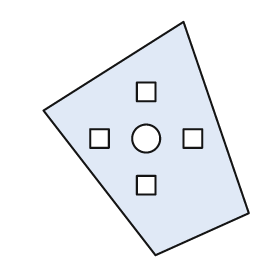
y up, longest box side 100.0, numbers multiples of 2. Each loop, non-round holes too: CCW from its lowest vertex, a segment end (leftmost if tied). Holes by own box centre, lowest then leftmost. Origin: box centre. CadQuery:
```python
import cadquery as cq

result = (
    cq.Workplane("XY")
    .moveTo(4.0, -50.0)
    .lineTo(44.0, -32.0)
    .lineTo(16.0, 50.0)
    .lineTo(-44.0, 12.0)
    .close()
    .moveTo(-4.0, -24.0)
    .lineTo(4.0, -24.0)
    .lineTo(4.0, -16.0)
    .lineTo(-4.0, -16.0)
    .close()
    .moveTo(-24.0, -4.0)
    .lineTo(-16.0, -4.0)
    .lineTo(-16.0, 4.0)
    .lineTo(-24.0, 4.0)
    .close()
    .moveTo(0.0, 0.0)
    .circle(6.0)
    .moveTo(16.0, -4.0)
    .lineTo(24.0, -4.0)
    .lineTo(24.0, 4.0)
    .lineTo(16.0, 4.0)
    .close()
    .moveTo(-4.0, 16.0)
    .lineTo(4.0, 16.0)
    .lineTo(4.0, 24.0)
    .lineTo(-4.0, 24.0)
    .close()
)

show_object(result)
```